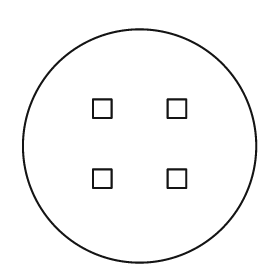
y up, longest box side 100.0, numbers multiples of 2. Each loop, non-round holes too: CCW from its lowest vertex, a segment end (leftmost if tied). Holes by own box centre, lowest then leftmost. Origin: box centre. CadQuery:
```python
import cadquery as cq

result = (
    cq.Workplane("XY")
    .moveTo(0.0, 0.0)
    .circle(50.0)
    .moveTo(-20.0, -18.0)
    .lineTo(-12.0, -18.0)
    .lineTo(-12.0, -10.0)
    .lineTo(-20.0, -10.0)
    .close()
    .moveTo(12.0, -18.0)
    .lineTo(20.0, -18.0)
    .lineTo(20.0, -10.0)
    .lineTo(12.0, -10.0)
    .close()
    .moveTo(-20.0, 12.0)
    .lineTo(-12.0, 12.0)
    .lineTo(-12.0, 20.0)
    .lineTo(-20.0, 20.0)
    .close()
    .moveTo(12.0, 12.0)
    .lineTo(20.0, 12.0)
    .lineTo(20.0, 20.0)
    .lineTo(12.0, 20.0)
    .close()
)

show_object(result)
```